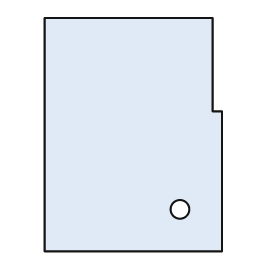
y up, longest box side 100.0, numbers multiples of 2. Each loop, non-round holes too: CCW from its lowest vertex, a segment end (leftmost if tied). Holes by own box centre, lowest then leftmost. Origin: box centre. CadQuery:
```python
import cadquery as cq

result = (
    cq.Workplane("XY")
    .moveTo(-38.0, -50.0)
    .lineTo(38.0, -50.0)
    .lineTo(38.0, 10.0)
    .lineTo(34.0, 10.0)
    .lineTo(34.0, 50.0)
    .lineTo(-38.0, 50.0)
    .close()
    .moveTo(20.0, -32.0)
    .circle(4.0)
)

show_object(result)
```